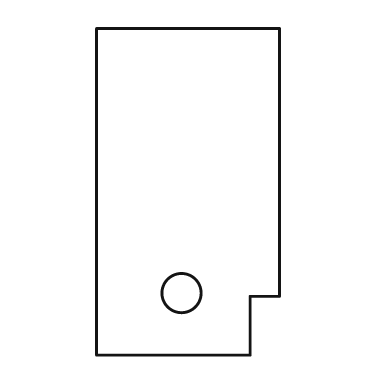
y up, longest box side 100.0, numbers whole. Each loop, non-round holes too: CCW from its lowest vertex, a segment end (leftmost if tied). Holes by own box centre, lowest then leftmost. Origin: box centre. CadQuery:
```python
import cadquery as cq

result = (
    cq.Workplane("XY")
    .moveTo(-28.0, -50.0)
    .lineTo(19.0, -50.0)
    .lineTo(19.0, -32.0)
    .lineTo(28.0, -32.0)
    .lineTo(28.0, 50.0)
    .lineTo(-28.0, 50.0)
    .close()
    .moveTo(-2.0, -31.0)
    .circle(6.0)
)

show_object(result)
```